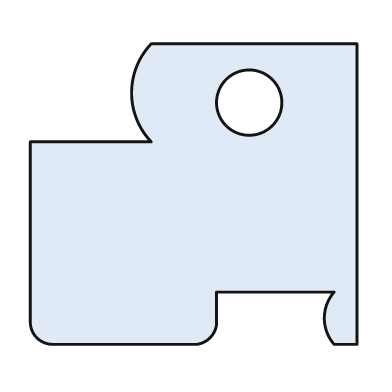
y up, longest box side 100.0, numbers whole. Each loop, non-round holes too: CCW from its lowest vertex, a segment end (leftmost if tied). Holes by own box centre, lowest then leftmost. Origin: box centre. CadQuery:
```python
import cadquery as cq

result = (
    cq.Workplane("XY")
    .moveTo(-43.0, -46.0)
    .lineTo(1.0, -46.0)
    .threePointArc((5.0, -44.0), (7.0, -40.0))
    .lineTo(7.0, -30.0)
    .lineTo(43.0, -30.0)
    .threePointArc((40.0, -38.0), (43.0, -46.0))
    .lineTo(50.0, -46.0)
    .lineTo(50.0, 46.0)
    .lineTo(-13.0, 46.0)
    .threePointArc((-19.0, 31.0), (-13.0, 16.0))
    .lineTo(-50.0, 16.0)
    .lineTo(-50.0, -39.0)
    .threePointArc((-48.0, -44.0), (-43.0, -46.0))
    .close()
    .moveTo(17.0, 28.0)
    .circle(10.0)
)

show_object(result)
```